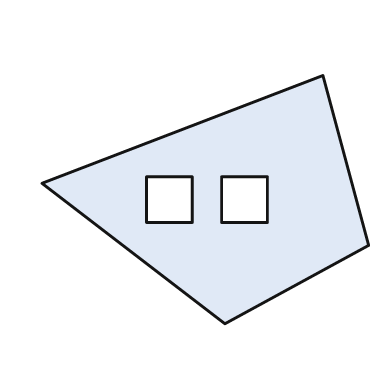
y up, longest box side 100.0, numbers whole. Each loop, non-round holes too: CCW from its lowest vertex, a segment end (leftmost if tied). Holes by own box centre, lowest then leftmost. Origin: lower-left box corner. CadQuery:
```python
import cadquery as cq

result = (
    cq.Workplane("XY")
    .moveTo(56.0, 0.0)
    .lineTo(100.0, 24.0)
    .lineTo(86.0, 76.0)
    .lineTo(0.0, 43.0)
    .close()
    .moveTo(32.0, 31.0)
    .lineTo(46.0, 31.0)
    .lineTo(46.0, 45.0)
    .lineTo(32.0, 45.0)
    .close()
    .moveTo(55.0, 31.0)
    .lineTo(69.0, 31.0)
    .lineTo(69.0, 45.0)
    .lineTo(55.0, 45.0)
    .close()
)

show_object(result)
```